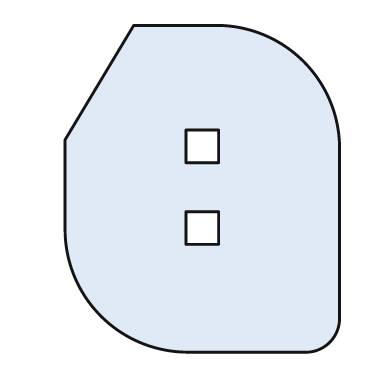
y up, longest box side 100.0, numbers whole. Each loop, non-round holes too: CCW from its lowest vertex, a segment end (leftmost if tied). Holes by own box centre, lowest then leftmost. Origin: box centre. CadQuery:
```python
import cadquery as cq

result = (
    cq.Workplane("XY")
    .moveTo(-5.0, -50.0)
    .lineTo(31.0, -50.0)
    .threePointArc((39.0, -47.0), (42.0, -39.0))
    .lineTo(42.0, 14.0)
    .threePointArc((31.0, 39.0), (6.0, 50.0))
    .lineTo(-21.0, 50.0)
    .lineTo(-42.0, 15.0)
    .lineTo(-42.0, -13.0)
    .threePointArc((-31.0, -39.0), (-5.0, -50.0))
    .close()
    .moveTo(-5.0, -17.0)
    .lineTo(5.0, -17.0)
    .lineTo(5.0, -7.0)
    .lineTo(-5.0, -7.0)
    .close()
    .moveTo(-5.0, 8.0)
    .lineTo(5.0, 8.0)
    .lineTo(5.0, 18.0)
    .lineTo(-5.0, 18.0)
    .close()
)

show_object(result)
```